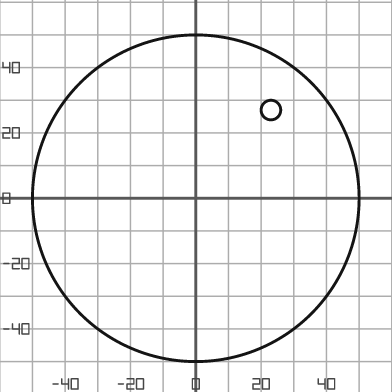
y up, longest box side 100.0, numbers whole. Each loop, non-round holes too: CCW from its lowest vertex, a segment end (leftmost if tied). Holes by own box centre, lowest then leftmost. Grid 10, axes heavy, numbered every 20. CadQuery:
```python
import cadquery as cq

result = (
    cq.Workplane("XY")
    .moveTo(0.0, 0.0)
    .circle(50.0)
    .moveTo(23.0, 27.0)
    .circle(3.0)
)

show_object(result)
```